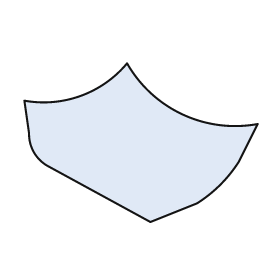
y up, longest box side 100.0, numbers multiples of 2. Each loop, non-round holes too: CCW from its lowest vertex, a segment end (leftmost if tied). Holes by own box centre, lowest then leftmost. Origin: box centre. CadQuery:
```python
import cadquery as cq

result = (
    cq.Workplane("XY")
    .moveTo(4.0, -34.0)
    .lineTo(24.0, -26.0)
    .threePointArc((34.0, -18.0), (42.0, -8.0))
    .lineTo(50.0, 8.0)
    .threePointArc((18.0, 12.0), (-6.0, 34.0))
    .threePointArc((-26.0, 20.0), (-50.0, 18.0))
    .lineTo(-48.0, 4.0)
    .threePointArc((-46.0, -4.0), (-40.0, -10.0))
    .close()
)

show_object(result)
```